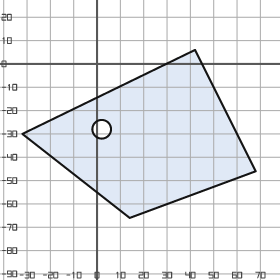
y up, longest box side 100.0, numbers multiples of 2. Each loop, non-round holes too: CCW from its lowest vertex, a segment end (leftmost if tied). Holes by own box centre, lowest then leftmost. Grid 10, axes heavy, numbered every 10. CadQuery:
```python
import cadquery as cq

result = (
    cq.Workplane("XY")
    .moveTo(14.0, -66.0)
    .lineTo(68.0, -46.0)
    .lineTo(42.0, 6.0)
    .lineTo(-32.0, -30.0)
    .close()
    .moveTo(2.0, -28.0)
    .circle(4.0)
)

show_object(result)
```